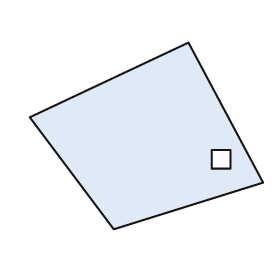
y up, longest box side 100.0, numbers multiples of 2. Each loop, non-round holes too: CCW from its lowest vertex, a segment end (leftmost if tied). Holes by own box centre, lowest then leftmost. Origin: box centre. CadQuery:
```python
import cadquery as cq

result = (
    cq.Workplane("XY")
    .moveTo(-14.0, -40.0)
    .lineTo(50.0, -20.0)
    .lineTo(18.0, 40.0)
    .lineTo(-50.0, 8.0)
    .close()
    .moveTo(28.0, -14.0)
    .lineTo(36.0, -14.0)
    .lineTo(36.0, -6.0)
    .lineTo(28.0, -6.0)
    .close()
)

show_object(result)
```